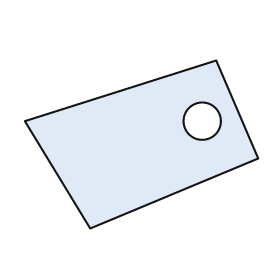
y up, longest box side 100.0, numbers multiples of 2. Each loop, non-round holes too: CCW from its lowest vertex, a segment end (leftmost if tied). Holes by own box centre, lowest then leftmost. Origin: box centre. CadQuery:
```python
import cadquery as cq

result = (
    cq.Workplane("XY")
    .moveTo(-22.0, -36.0)
    .lineTo(50.0, -6.0)
    .lineTo(32.0, 36.0)
    .lineTo(-50.0, 10.0)
    .close()
    .moveTo(26.0, 10.0)
    .circle(8.0)
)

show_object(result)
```